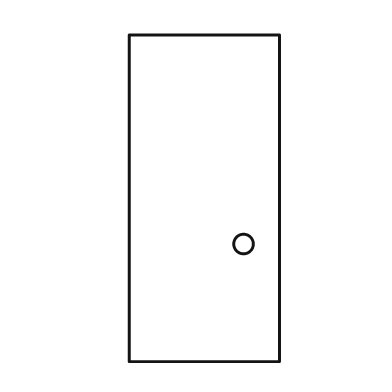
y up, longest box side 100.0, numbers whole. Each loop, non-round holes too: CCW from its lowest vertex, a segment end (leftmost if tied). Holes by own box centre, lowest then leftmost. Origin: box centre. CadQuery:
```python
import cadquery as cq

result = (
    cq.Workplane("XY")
    .moveTo(-23.0, -50.0)
    .lineTo(23.0, -50.0)
    .lineTo(23.0, 50.0)
    .lineTo(-23.0, 50.0)
    .close()
    .moveTo(12.0, -14.0)
    .circle(3.0)
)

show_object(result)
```